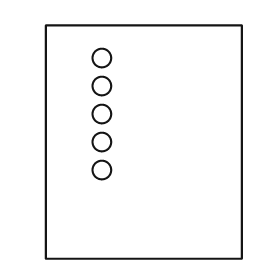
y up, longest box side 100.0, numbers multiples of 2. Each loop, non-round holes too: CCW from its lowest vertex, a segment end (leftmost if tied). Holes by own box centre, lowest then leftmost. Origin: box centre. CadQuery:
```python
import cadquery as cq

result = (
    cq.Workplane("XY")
    .moveTo(-42.0, -50.0)
    .lineTo(42.0, -50.0)
    .lineTo(42.0, 50.0)
    .lineTo(-42.0, 50.0)
    .close()
    .moveTo(-18.0, -12.0)
    .circle(4.0)
    .moveTo(-18.0, 0.0)
    .circle(4.0)
    .moveTo(-18.0, 12.0)
    .circle(4.0)
    .moveTo(-18.0, 24.0)
    .circle(4.0)
    .moveTo(-18.0, 36.0)
    .circle(4.0)
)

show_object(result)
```